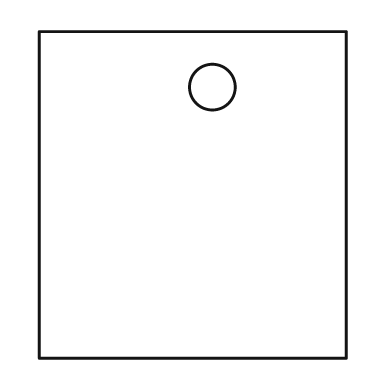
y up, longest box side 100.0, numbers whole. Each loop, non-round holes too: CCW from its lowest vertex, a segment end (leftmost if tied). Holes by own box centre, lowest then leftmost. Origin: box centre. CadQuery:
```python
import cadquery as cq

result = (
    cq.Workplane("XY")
    .moveTo(-47.0, -50.0)
    .lineTo(47.0, -50.0)
    .lineTo(47.0, 50.0)
    .lineTo(-47.0, 50.0)
    .close()
    .moveTo(6.0, 33.0)
    .circle(7.0)
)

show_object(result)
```